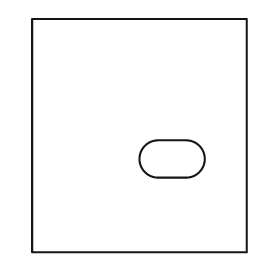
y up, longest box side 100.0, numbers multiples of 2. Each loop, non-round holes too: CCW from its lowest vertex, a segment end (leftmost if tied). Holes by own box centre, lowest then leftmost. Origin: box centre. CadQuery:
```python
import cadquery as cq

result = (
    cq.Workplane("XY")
    .moveTo(-46.0, -50.0)
    .lineTo(46.0, -50.0)
    .lineTo(46.0, 50.0)
    .lineTo(-46.0, 50.0)
    .close()
    .moveTo(8.0, -18.0)
    .lineTo(20.0, -18.0)
    .threePointArc((28.0, -10.0), (20.0, -2.0))
    .lineTo(8.0, -2.0)
    .threePointArc((0.0, -10.0), (8.0, -18.0))
    .close()
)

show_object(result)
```